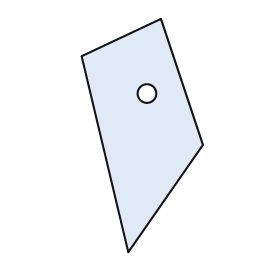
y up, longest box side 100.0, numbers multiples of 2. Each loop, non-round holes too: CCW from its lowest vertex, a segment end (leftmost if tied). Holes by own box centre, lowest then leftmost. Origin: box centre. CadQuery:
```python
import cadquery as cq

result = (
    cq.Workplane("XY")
    .moveTo(-6.0, -50.0)
    .lineTo(26.0, -4.0)
    .lineTo(8.0, 50.0)
    .lineTo(-26.0, 34.0)
    .close()
    .moveTo(2.0, 18.0)
    .circle(4.0)
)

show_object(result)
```